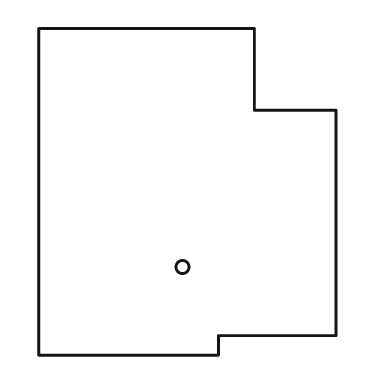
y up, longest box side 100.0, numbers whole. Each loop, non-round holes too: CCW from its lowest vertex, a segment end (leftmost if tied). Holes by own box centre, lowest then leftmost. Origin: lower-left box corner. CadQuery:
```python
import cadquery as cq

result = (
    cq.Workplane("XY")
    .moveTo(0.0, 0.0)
    .lineTo(55.0, 0.0)
    .lineTo(55.0, 6.0)
    .lineTo(91.0, 6.0)
    .lineTo(91.0, 75.0)
    .lineTo(66.0, 75.0)
    .lineTo(66.0, 100.0)
    .lineTo(0.0, 100.0)
    .close()
    .moveTo(44.0, 27.0)
    .circle(2.0)
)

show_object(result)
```